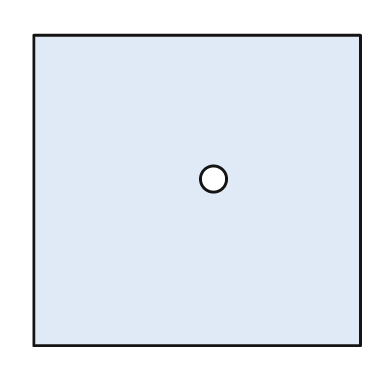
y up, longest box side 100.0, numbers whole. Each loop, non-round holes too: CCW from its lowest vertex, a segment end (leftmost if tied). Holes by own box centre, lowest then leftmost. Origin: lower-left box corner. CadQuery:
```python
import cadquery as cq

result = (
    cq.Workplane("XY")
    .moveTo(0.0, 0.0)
    .lineTo(100.0, 0.0)
    .lineTo(100.0, 95.0)
    .lineTo(0.0, 95.0)
    .close()
    .moveTo(55.0, 51.0)
    .circle(4.0)
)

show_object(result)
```